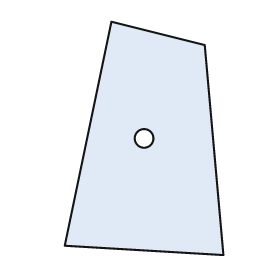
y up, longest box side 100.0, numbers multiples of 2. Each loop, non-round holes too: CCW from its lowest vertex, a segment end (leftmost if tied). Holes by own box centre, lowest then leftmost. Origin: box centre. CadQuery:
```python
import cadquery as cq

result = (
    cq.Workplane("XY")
    .moveTo(34.0, -50.0)
    .lineTo(26.0, 40.0)
    .lineTo(-14.0, 50.0)
    .lineTo(-34.0, -46.0)
    .close()
    .moveTo(0.0, 0.0)
    .circle(4.0)
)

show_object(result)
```